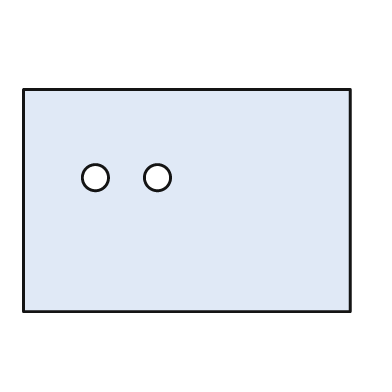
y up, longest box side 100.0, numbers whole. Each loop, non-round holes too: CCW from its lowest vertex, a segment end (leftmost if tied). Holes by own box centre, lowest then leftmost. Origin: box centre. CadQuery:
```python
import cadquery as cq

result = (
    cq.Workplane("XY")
    .moveTo(-50.0, -34.0)
    .lineTo(50.0, -34.0)
    .lineTo(50.0, 34.0)
    .lineTo(-50.0, 34.0)
    .close()
    .moveTo(-28.0, 7.0)
    .circle(4.0)
    .moveTo(-9.0, 7.0)
    .circle(4.0)
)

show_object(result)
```